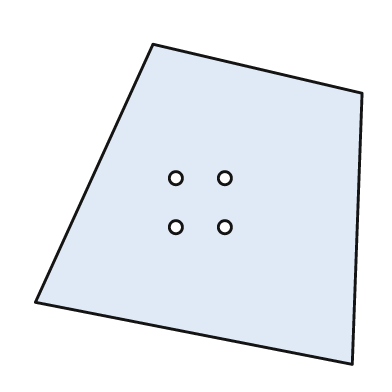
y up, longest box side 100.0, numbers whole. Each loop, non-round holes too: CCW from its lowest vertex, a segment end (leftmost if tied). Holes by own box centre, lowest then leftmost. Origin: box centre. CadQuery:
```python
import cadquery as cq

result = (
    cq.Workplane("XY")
    .moveTo(47.0, -49.0)
    .lineTo(50.0, 34.0)
    .lineTo(-14.0, 49.0)
    .lineTo(-50.0, -30.0)
    .close()
    .moveTo(-7.0, -7.0)
    .circle(2.0)
    .moveTo(8.0, -7.0)
    .circle(2.0)
    .moveTo(-7.0, 8.0)
    .circle(2.0)
    .moveTo(8.0, 8.0)
    .circle(2.0)
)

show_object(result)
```